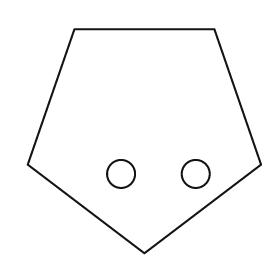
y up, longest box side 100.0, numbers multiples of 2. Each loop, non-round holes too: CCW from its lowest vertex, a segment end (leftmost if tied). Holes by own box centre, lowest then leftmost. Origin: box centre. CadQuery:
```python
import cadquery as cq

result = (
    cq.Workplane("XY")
    .moveTo(0.0, -48.0)
    .lineTo(50.0, -10.0)
    .lineTo(30.0, 48.0)
    .lineTo(-30.0, 48.0)
    .lineTo(-50.0, -10.0)
    .close()
    .moveTo(-10.0, -14.0)
    .circle(6.0)
    .moveTo(22.0, -14.0)
    .circle(6.0)
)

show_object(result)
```